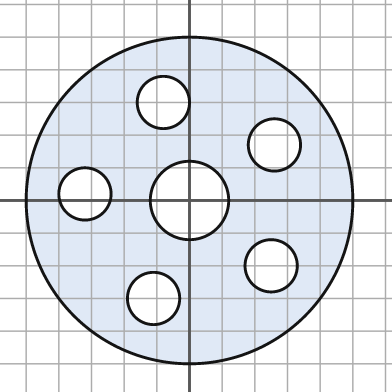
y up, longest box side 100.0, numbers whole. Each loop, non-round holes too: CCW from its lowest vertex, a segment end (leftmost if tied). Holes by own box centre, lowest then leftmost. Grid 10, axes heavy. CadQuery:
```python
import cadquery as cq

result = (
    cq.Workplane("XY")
    .moveTo(0.0, 0.0)
    .circle(50.0)
    .moveTo(-11.0, -30.0)
    .circle(8.0)
    .moveTo(25.0, -20.0)
    .circle(8.0)
    .moveTo(0.0, 0.0)
    .circle(12.0)
    .moveTo(-32.0, 2.0)
    .circle(8.0)
    .moveTo(26.0, 17.0)
    .circle(8.0)
    .moveTo(-8.0, 30.0)
    .circle(8.0)
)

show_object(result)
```